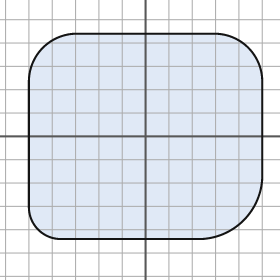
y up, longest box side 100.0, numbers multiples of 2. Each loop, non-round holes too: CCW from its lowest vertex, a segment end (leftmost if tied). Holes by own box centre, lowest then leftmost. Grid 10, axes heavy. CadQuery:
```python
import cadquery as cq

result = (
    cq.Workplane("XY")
    .moveTo(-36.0, -44.0)
    .lineTo(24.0, -44.0)
    .threePointArc((42.0, -36.0), (50.0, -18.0))
    .lineTo(50.0, 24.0)
    .threePointArc((44.0, 38.0), (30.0, 44.0))
    .lineTo(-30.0, 44.0)
    .threePointArc((-44.0, 38.0), (-50.0, 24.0))
    .lineTo(-50.0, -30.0)
    .threePointArc((-46.0, -40.0), (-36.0, -44.0))
    .close()
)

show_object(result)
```